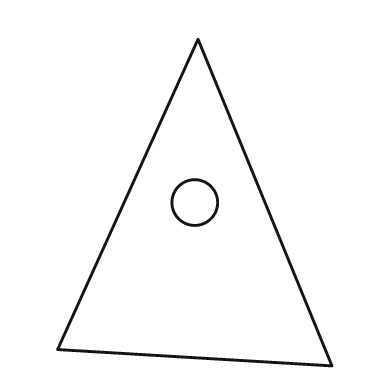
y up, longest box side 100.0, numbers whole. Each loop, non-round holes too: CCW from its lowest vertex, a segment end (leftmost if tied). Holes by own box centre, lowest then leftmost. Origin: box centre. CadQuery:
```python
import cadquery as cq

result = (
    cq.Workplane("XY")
    .moveTo(42.0, -50.0)
    .lineTo(1.0, 50.0)
    .lineTo(-42.0, -45.0)
    .close()
    .moveTo(0.0, 0.0)
    .circle(7.0)
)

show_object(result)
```